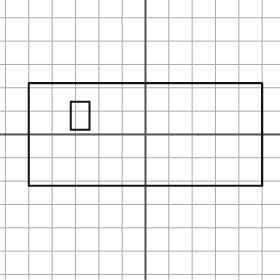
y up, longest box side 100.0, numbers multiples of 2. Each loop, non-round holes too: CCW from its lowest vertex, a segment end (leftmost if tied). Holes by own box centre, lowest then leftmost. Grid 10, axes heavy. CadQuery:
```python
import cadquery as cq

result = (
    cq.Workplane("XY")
    .moveTo(-50.0, -22.0)
    .lineTo(50.0, -22.0)
    .lineTo(50.0, 22.0)
    .lineTo(-50.0, 22.0)
    .close()
    .moveTo(-32.0, 2.0)
    .lineTo(-24.0, 2.0)
    .lineTo(-24.0, 14.0)
    .lineTo(-32.0, 14.0)
    .close()
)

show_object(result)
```